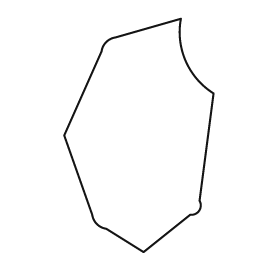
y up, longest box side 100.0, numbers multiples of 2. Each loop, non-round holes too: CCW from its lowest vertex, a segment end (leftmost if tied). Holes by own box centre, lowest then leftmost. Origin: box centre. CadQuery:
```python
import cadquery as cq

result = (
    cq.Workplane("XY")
    .moveTo(2.0, -50.0)
    .lineTo(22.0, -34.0)
    .threePointArc((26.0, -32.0), (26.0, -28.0))
    .lineTo(32.0, 18.0)
    .threePointArc((20.0, 32.0), (18.0, 50.0))
    .lineTo(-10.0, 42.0)
    .threePointArc((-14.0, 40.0), (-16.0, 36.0))
    .lineTo(-32.0, 0.0)
    .lineTo(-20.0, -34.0)
    .threePointArc((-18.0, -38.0), (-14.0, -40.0))
    .close()
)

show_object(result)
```